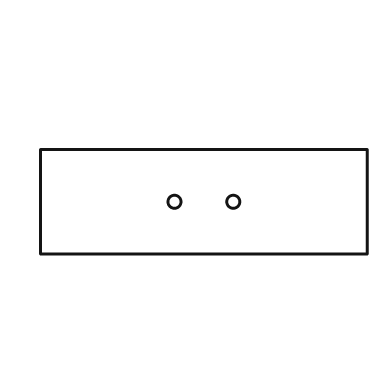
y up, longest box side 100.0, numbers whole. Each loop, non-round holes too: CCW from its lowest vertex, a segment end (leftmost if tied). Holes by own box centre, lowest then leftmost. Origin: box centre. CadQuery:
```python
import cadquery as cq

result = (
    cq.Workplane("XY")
    .moveTo(-50.0, -16.0)
    .lineTo(50.0, -16.0)
    .lineTo(50.0, 16.0)
    .lineTo(-50.0, 16.0)
    .close()
    .moveTo(-9.0, 0.0)
    .circle(2.0)
    .moveTo(9.0, 0.0)
    .circle(2.0)
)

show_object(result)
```